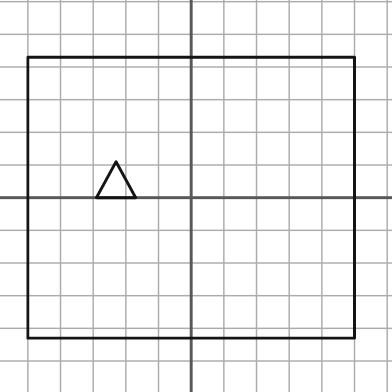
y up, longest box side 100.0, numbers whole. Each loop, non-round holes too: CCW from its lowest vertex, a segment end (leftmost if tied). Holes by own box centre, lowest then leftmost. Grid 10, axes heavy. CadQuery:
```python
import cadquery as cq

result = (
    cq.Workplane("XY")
    .moveTo(-50.0, -43.0)
    .lineTo(50.0, -43.0)
    .lineTo(50.0, 43.0)
    .lineTo(-50.0, 43.0)
    .close()
    .moveTo(-29.0, 0.0)
    .lineTo(-17.0, 0.0)
    .lineTo(-23.0, 11.0)
    .close()
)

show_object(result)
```